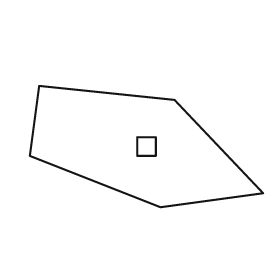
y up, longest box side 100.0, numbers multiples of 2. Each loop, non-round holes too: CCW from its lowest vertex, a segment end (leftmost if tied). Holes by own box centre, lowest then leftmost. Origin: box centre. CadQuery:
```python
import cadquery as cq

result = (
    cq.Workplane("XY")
    .moveTo(6.0, -26.0)
    .lineTo(50.0, -20.0)
    .lineTo(12.0, 20.0)
    .lineTo(-46.0, 26.0)
    .lineTo(-50.0, -4.0)
    .close()
    .moveTo(-4.0, -4.0)
    .lineTo(4.0, -4.0)
    .lineTo(4.0, 4.0)
    .lineTo(-4.0, 4.0)
    .close()
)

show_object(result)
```